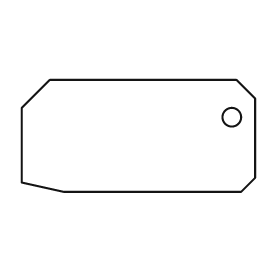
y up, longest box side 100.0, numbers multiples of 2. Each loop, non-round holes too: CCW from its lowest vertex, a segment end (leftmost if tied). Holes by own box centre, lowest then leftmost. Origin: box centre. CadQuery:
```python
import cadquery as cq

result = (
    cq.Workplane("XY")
    .moveTo(-32.0, -24.0)
    .lineTo(44.0, -24.0)
    .lineTo(50.0, -18.0)
    .lineTo(50.0, 16.0)
    .lineTo(42.0, 24.0)
    .lineTo(-38.0, 24.0)
    .lineTo(-50.0, 12.0)
    .lineTo(-50.0, -20.0)
    .close()
    .moveTo(40.0, 8.0)
    .circle(4.0)
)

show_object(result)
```